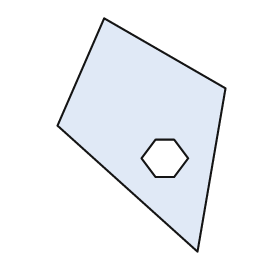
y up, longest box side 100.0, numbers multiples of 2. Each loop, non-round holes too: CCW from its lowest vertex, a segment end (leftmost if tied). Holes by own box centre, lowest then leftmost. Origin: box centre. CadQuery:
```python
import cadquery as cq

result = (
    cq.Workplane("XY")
    .moveTo(24.0, -50.0)
    .lineTo(36.0, 20.0)
    .lineTo(-16.0, 50.0)
    .lineTo(-36.0, 4.0)
    .close()
    .moveTo(6.0, -18.0)
    .lineTo(14.0, -18.0)
    .lineTo(20.0, -10.0)
    .lineTo(14.0, -2.0)
    .lineTo(6.0, -2.0)
    .lineTo(0.0, -10.0)
    .close()
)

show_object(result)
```